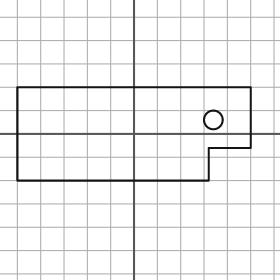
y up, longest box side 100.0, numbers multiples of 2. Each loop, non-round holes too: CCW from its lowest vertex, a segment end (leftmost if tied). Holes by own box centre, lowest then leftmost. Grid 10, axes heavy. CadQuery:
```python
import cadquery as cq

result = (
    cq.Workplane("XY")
    .moveTo(-50.0, -20.0)
    .lineTo(32.0, -20.0)
    .lineTo(32.0, -6.0)
    .lineTo(50.0, -6.0)
    .lineTo(50.0, 20.0)
    .lineTo(-50.0, 20.0)
    .close()
    .moveTo(34.0, 6.0)
    .circle(4.0)
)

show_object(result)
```